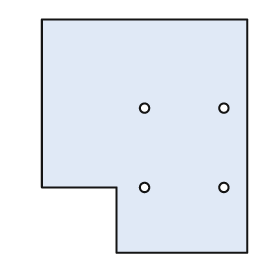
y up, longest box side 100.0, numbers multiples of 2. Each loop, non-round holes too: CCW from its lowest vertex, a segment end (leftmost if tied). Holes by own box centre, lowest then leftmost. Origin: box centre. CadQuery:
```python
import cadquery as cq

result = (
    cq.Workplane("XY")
    .moveTo(-12.0, -50.0)
    .lineTo(44.0, -50.0)
    .lineTo(44.0, 50.0)
    .lineTo(-44.0, 50.0)
    .lineTo(-44.0, -22.0)
    .lineTo(-12.0, -22.0)
    .close()
    .moveTo(0.0, -22.0)
    .circle(2.0)
    .moveTo(34.0, -22.0)
    .circle(2.0)
    .moveTo(0.0, 12.0)
    .circle(2.0)
    .moveTo(34.0, 12.0)
    .circle(2.0)
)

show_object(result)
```